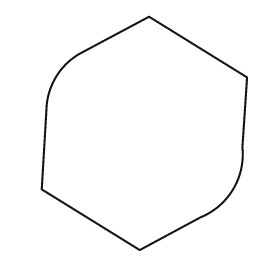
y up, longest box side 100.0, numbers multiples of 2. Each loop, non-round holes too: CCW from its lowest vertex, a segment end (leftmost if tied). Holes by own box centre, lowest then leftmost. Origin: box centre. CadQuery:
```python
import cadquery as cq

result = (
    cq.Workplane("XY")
    .moveTo(-2.0, -50.0)
    .lineTo(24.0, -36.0)
    .threePointArc((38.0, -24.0), (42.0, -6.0))
    .lineTo(44.0, 24.0)
    .lineTo(2.0, 50.0)
    .lineTo(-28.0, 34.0)
    .threePointArc((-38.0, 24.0), (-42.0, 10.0))
    .lineTo(-44.0, -24.0)
    .close()
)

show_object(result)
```